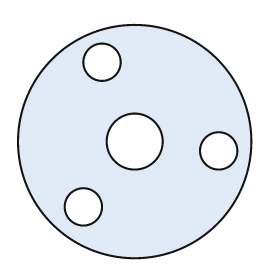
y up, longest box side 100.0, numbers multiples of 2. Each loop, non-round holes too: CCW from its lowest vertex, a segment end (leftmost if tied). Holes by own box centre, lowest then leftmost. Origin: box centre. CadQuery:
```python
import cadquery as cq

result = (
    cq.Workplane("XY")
    .moveTo(0.0, 0.0)
    .circle(50.0)
    .moveTo(-22.0, -28.0)
    .circle(8.0)
    .moveTo(36.0, -4.0)
    .circle(8.0)
    .moveTo(0.0, 0.0)
    .circle(12.0)
    .moveTo(-14.0, 34.0)
    .circle(8.0)
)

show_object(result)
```